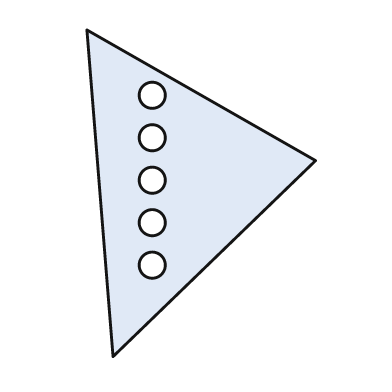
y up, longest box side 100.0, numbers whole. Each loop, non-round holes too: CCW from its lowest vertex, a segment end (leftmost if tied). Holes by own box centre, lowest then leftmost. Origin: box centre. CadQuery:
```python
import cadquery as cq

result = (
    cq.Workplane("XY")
    .moveTo(-27.0, -50.0)
    .lineTo(35.0, 10.0)
    .lineTo(-35.0, 50.0)
    .close()
    .moveTo(-15.0, -22.0)
    .circle(4.0)
    .moveTo(-15.0, -9.0)
    .circle(4.0)
    .moveTo(-15.0, 4.0)
    .circle(4.0)
    .moveTo(-15.0, 17.0)
    .circle(4.0)
    .moveTo(-15.0, 30.0)
    .circle(4.0)
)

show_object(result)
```